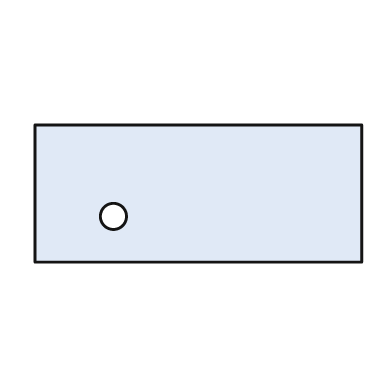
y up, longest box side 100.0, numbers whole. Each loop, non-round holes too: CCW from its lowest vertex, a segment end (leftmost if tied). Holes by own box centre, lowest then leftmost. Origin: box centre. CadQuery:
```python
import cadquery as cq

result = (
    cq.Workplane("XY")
    .moveTo(-50.0, -21.0)
    .lineTo(50.0, -21.0)
    .lineTo(50.0, 21.0)
    .lineTo(-50.0, 21.0)
    .close()
    .moveTo(-26.0, -7.0)
    .circle(4.0)
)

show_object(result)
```